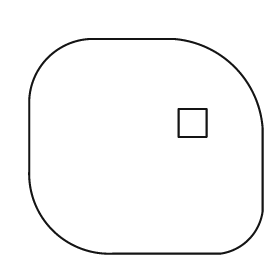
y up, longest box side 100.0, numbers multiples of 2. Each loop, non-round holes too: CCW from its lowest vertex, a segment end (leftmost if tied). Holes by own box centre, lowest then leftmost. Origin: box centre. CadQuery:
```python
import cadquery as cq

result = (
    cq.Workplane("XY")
    .moveTo(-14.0, -46.0)
    .lineTo(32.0, -46.0)
    .threePointArc((44.0, -40.0), (50.0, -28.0))
    .lineTo(50.0, 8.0)
    .threePointArc((38.0, 34.0), (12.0, 46.0))
    .lineTo(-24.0, 46.0)
    .threePointArc((-42.0, 38.0), (-50.0, 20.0))
    .lineTo(-50.0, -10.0)
    .threePointArc((-40.0, -36.0), (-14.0, -46.0))
    .close()
    .moveTo(14.0, 4.0)
    .lineTo(26.0, 4.0)
    .lineTo(26.0, 16.0)
    .lineTo(14.0, 16.0)
    .close()
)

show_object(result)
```